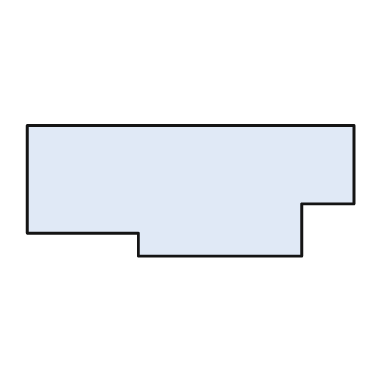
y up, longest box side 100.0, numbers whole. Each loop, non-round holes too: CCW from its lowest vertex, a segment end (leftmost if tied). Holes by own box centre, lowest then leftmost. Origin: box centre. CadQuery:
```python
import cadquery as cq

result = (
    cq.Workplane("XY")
    .moveTo(-16.0, -20.0)
    .lineTo(34.0, -20.0)
    .lineTo(34.0, -4.0)
    .lineTo(50.0, -4.0)
    .lineTo(50.0, 20.0)
    .lineTo(-50.0, 20.0)
    .lineTo(-50.0, -13.0)
    .lineTo(-16.0, -13.0)
    .close()
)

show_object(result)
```